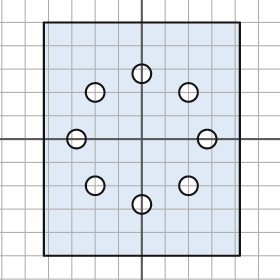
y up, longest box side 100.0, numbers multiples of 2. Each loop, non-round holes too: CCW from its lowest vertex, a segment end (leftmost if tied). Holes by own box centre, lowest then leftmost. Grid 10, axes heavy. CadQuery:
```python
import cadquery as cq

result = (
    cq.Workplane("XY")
    .moveTo(-42.0, -50.0)
    .lineTo(42.0, -50.0)
    .lineTo(42.0, 50.0)
    .lineTo(-42.0, 50.0)
    .close()
    .moveTo(0.0, -28.0)
    .circle(4.0)
    .moveTo(-20.0, -20.0)
    .circle(4.0)
    .moveTo(20.0, -20.0)
    .circle(4.0)
    .moveTo(-28.0, 0.0)
    .circle(4.0)
    .moveTo(28.0, 0.0)
    .circle(4.0)
    .moveTo(-20.0, 20.0)
    .circle(4.0)
    .moveTo(20.0, 20.0)
    .circle(4.0)
    .moveTo(0.0, 28.0)
    .circle(4.0)
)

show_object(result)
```